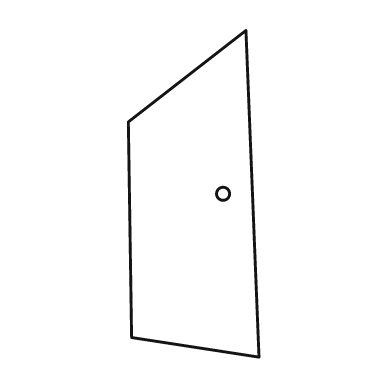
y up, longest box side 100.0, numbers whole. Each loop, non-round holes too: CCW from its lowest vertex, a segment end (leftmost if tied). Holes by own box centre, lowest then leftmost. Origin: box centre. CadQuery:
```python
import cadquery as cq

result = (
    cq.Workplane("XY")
    .moveTo(20.0, -50.0)
    .lineTo(16.0, 50.0)
    .lineTo(-20.0, 22.0)
    .lineTo(-19.0, -44.0)
    .close()
    .moveTo(9.0, 0.0)
    .circle(2.0)
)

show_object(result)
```